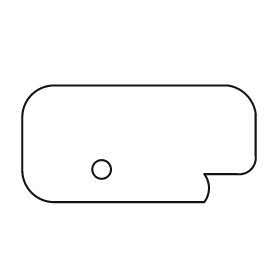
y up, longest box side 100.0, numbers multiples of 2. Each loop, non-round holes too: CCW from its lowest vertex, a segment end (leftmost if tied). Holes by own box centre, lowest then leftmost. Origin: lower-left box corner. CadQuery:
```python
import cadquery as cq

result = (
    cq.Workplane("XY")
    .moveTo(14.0, 0.0)
    .lineTo(78.0, 0.0)
    .threePointArc((80.0, 6.0), (78.0, 12.0))
    .lineTo(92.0, 12.0)
    .threePointArc((98.0, 14.0), (100.0, 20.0))
    .lineTo(100.0, 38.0)
    .threePointArc((96.0, 46.0), (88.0, 50.0))
    .lineTo(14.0, 50.0)
    .threePointArc((4.0, 46.0), (0.0, 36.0))
    .lineTo(0.0, 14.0)
    .threePointArc((4.0, 4.0), (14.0, 0.0))
    .close()
    .moveTo(34.0, 14.0)
    .circle(4.0)
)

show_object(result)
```